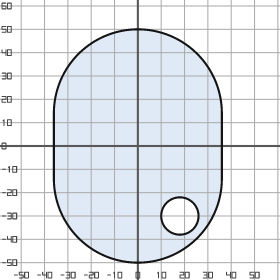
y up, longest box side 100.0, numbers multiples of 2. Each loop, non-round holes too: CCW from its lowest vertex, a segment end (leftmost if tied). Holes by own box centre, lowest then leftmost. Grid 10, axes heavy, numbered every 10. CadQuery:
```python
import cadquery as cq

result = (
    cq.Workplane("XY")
    .moveTo(-36.0, -14.0)
    .threePointArc((0.0, -50.0), (36.0, -14.0))
    .lineTo(36.0, 14.0)
    .threePointArc((0.0, 50.0), (-36.0, 14.0))
    .close()
    .moveTo(18.0, -30.0)
    .circle(8.0)
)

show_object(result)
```